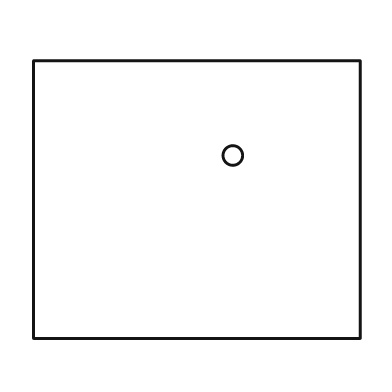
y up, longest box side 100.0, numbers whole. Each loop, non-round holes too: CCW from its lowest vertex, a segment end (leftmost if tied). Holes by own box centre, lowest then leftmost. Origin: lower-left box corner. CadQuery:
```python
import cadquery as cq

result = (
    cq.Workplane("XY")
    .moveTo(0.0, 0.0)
    .lineTo(100.0, 0.0)
    .lineTo(100.0, 85.0)
    .lineTo(0.0, 85.0)
    .close()
    .moveTo(61.0, 56.0)
    .circle(3.0)
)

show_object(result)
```